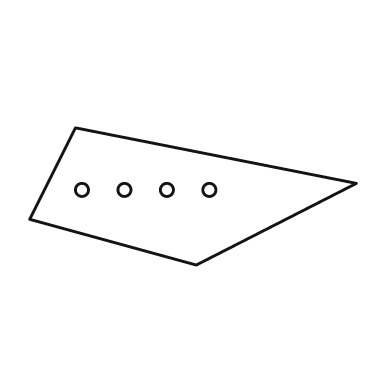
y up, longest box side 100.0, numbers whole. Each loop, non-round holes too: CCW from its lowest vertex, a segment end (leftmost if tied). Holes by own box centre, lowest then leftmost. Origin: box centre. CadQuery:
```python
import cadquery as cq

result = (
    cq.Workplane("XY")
    .moveTo(1.0, -21.0)
    .lineTo(50.0, 4.0)
    .lineTo(-36.0, 21.0)
    .lineTo(-50.0, -7.0)
    .close()
    .moveTo(-34.0, 2.0)
    .circle(2.0)
    .moveTo(-21.0, 2.0)
    .circle(2.0)
    .moveTo(-8.0, 2.0)
    .circle(2.0)
    .moveTo(5.0, 2.0)
    .circle(2.0)
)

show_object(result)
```